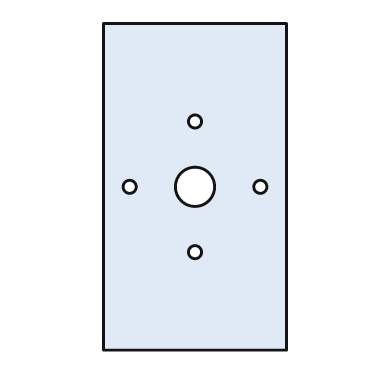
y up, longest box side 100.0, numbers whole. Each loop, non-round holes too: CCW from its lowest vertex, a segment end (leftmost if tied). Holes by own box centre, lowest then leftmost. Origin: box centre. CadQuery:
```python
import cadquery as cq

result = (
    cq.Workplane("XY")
    .moveTo(-28.0, -50.0)
    .lineTo(28.0, -50.0)
    .lineTo(28.0, 50.0)
    .lineTo(-28.0, 50.0)
    .close()
    .moveTo(0.0, -20.0)
    .circle(2.0)
    .moveTo(-20.0, 0.0)
    .circle(2.0)
    .moveTo(0.0, 0.0)
    .circle(6.0)
    .moveTo(20.0, 0.0)
    .circle(2.0)
    .moveTo(0.0, 20.0)
    .circle(2.0)
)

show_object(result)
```